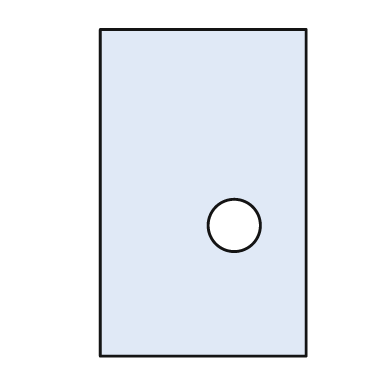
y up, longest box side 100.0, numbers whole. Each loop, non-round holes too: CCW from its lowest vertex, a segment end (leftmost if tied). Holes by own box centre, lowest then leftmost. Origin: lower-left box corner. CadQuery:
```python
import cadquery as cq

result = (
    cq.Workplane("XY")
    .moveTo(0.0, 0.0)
    .lineTo(63.0, 0.0)
    .lineTo(63.0, 100.0)
    .lineTo(0.0, 100.0)
    .close()
    .moveTo(41.0, 40.0)
    .circle(8.0)
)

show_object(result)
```